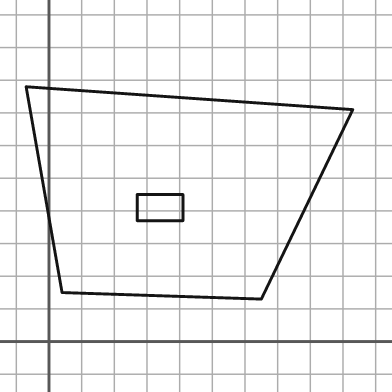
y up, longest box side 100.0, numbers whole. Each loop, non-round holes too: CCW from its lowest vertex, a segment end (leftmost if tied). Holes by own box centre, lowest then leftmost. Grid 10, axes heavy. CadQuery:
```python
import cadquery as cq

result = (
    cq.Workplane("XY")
    .moveTo(65.0, 13.0)
    .lineTo(93.0, 71.0)
    .lineTo(-7.0, 78.0)
    .lineTo(4.0, 15.0)
    .close()
    .moveTo(27.0, 37.0)
    .lineTo(41.0, 37.0)
    .lineTo(41.0, 45.0)
    .lineTo(27.0, 45.0)
    .close()
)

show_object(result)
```